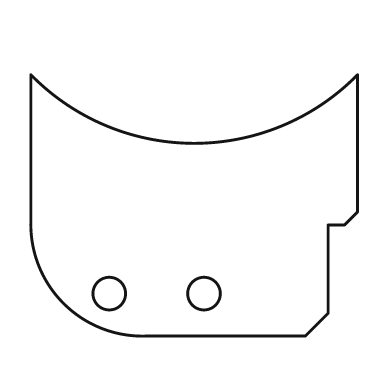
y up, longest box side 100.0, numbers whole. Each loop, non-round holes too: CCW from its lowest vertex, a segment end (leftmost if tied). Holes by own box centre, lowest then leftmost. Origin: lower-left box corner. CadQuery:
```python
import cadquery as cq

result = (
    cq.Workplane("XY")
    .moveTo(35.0, 0.0)
    .lineTo(84.0, 0.0)
    .lineTo(91.0, 7.0)
    .lineTo(91.0, 34.0)
    .lineTo(96.0, 34.0)
    .lineTo(100.0, 38.0)
    .lineTo(100.0, 80.0)
    .threePointArc((50.0, 59.0), (0.0, 80.0))
    .lineTo(0.0, 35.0)
    .threePointArc((10.0, 10.0), (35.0, 0.0))
    .close()
    .moveTo(24.0, 13.0)
    .circle(5.0)
    .moveTo(53.0, 13.0)
    .circle(5.0)
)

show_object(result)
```